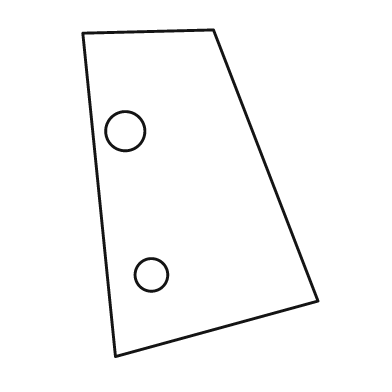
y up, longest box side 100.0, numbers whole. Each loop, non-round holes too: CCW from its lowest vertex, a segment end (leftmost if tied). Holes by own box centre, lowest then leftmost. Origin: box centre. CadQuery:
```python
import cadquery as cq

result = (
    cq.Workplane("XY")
    .moveTo(-26.0, -50.0)
    .lineTo(36.0, -33.0)
    .lineTo(4.0, 50.0)
    .lineTo(-36.0, 49.0)
    .close()
    .moveTo(-15.0, -25.0)
    .circle(5.0)
    .moveTo(-23.0, 19.0)
    .circle(6.0)
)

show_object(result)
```